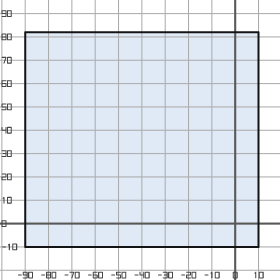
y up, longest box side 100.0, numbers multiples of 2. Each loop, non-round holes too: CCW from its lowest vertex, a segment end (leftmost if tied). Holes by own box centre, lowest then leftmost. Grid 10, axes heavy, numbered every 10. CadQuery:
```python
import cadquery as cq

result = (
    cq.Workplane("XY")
    .moveTo(-90.0, -10.0)
    .lineTo(10.0, -10.0)
    .lineTo(10.0, 82.0)
    .lineTo(-90.0, 82.0)
    .close()
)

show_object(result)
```